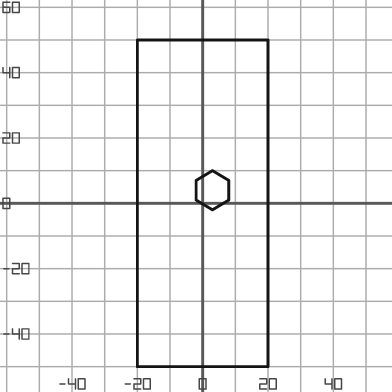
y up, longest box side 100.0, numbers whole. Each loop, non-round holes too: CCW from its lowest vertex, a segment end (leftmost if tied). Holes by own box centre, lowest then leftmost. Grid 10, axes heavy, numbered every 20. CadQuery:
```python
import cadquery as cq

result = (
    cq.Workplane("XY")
    .moveTo(-20.0, -50.0)
    .lineTo(20.0, -50.0)
    .lineTo(20.0, 50.0)
    .lineTo(-20.0, 50.0)
    .close()
    .moveTo(3.0, -2.0)
    .lineTo(8.0, 1.0)
    .lineTo(8.0, 7.0)
    .lineTo(3.0, 10.0)
    .lineTo(-2.0, 7.0)
    .lineTo(-2.0, 1.0)
    .close()
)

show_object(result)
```